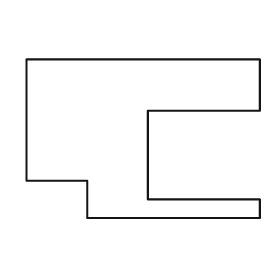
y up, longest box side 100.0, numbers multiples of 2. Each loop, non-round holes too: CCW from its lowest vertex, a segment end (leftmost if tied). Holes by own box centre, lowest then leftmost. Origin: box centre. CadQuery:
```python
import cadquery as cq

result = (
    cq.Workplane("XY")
    .moveTo(-24.0, -34.0)
    .lineTo(50.0, -34.0)
    .lineTo(50.0, -26.0)
    .lineTo(2.0, -26.0)
    .lineTo(2.0, 12.0)
    .lineTo(50.0, 12.0)
    .lineTo(50.0, 34.0)
    .lineTo(-50.0, 34.0)
    .lineTo(-50.0, -18.0)
    .lineTo(-24.0, -18.0)
    .close()
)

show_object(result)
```